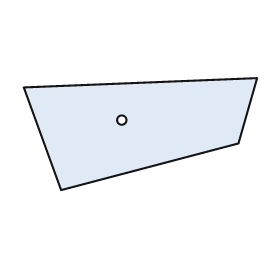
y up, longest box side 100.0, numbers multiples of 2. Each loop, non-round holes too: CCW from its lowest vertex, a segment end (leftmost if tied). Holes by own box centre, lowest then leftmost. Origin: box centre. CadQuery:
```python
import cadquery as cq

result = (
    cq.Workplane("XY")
    .moveTo(-34.0, -24.0)
    .lineTo(42.0, -4.0)
    .lineTo(50.0, 24.0)
    .lineTo(-50.0, 20.0)
    .close()
    .moveTo(-8.0, 6.0)
    .circle(2.0)
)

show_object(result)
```